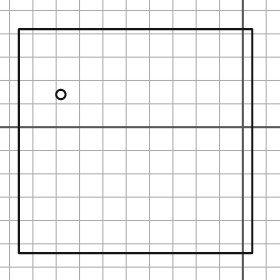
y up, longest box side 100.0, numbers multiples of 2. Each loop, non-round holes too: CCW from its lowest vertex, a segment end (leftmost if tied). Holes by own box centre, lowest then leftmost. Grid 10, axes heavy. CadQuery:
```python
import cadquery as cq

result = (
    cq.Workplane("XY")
    .moveTo(-96.0, -54.0)
    .lineTo(4.0, -54.0)
    .lineTo(4.0, 42.0)
    .lineTo(-96.0, 42.0)
    .close()
    .moveTo(-78.0, 14.0)
    .circle(2.0)
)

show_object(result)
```